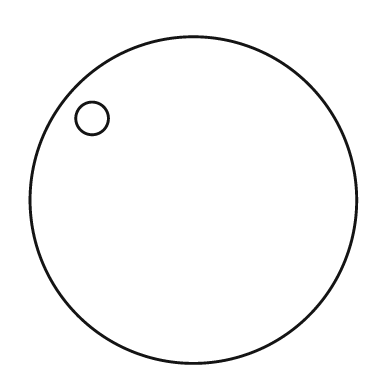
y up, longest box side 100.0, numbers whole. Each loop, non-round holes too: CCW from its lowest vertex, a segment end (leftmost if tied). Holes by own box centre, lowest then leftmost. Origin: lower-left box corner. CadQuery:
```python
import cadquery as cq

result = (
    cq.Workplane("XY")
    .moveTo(50.0, 50.0)
    .circle(50.0)
    .moveTo(19.0, 75.0)
    .circle(5.0)
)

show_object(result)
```